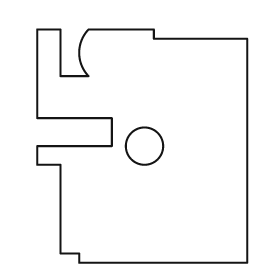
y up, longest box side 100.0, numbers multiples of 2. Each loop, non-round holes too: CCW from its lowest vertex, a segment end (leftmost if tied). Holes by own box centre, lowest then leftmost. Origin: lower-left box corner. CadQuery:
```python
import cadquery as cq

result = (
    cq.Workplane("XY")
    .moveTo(18.0, 0.0)
    .lineTo(90.0, 0.0)
    .lineTo(90.0, 96.0)
    .lineTo(50.0, 96.0)
    .lineTo(50.0, 100.0)
    .lineTo(22.0, 100.0)
    .threePointArc((18.0, 90.0), (22.0, 80.0))
    .lineTo(10.0, 80.0)
    .lineTo(10.0, 100.0)
    .lineTo(0.0, 100.0)
    .lineTo(0.0, 62.0)
    .lineTo(32.0, 62.0)
    .lineTo(32.0, 50.0)
    .lineTo(0.0, 50.0)
    .lineTo(0.0, 42.0)
    .lineTo(10.0, 42.0)
    .lineTo(10.0, 4.0)
    .lineTo(18.0, 4.0)
    .close()
    .moveTo(46.0, 50.0)
    .circle(8.0)
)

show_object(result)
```